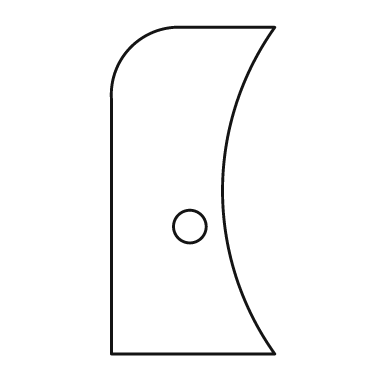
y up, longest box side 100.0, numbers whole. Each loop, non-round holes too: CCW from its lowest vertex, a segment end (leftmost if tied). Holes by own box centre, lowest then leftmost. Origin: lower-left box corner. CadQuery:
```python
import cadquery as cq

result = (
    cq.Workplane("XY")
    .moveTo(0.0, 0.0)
    .lineTo(50.0, 0.0)
    .threePointArc((34.0, 50.0), (50.0, 100.0))
    .lineTo(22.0, 100.0)
    .threePointArc((6.0, 94.0), (0.0, 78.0))
    .close()
    .moveTo(24.0, 39.0)
    .circle(5.0)
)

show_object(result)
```